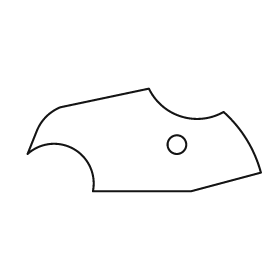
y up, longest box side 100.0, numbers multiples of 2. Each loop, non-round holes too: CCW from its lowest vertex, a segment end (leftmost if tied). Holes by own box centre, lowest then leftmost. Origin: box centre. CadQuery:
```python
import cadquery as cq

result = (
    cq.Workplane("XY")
    .moveTo(-22.0, -22.0)
    .lineTo(20.0, -22.0)
    .lineTo(50.0, -14.0)
    .threePointArc((44.0, 0.0), (34.0, 12.0))
    .threePointArc((16.0, 10.0), (2.0, 22.0))
    .lineTo(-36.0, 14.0)
    .threePointArc((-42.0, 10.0), (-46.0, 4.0))
    .lineTo(-50.0, -6.0)
    .threePointArc((-30.0, -4.0), (-22.0, -22.0))
    .close()
    .moveTo(14.0, -2.0)
    .circle(4.0)
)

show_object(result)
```